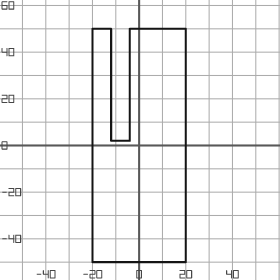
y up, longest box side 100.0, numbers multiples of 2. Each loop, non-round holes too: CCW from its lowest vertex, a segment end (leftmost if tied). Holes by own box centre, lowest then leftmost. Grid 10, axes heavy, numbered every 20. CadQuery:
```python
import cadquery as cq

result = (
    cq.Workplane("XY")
    .moveTo(-20.0, -50.0)
    .lineTo(20.0, -50.0)
    .lineTo(20.0, 50.0)
    .lineTo(-4.0, 50.0)
    .lineTo(-4.0, 2.0)
    .lineTo(-12.0, 2.0)
    .lineTo(-12.0, 50.0)
    .lineTo(-20.0, 50.0)
    .close()
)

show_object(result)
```